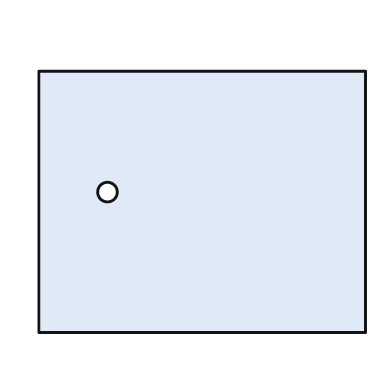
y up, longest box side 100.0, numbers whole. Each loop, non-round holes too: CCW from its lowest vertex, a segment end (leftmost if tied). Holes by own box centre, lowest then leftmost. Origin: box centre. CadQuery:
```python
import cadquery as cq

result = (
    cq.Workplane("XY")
    .moveTo(-50.0, -40.0)
    .lineTo(50.0, -40.0)
    .lineTo(50.0, 40.0)
    .lineTo(-50.0, 40.0)
    .close()
    .moveTo(-29.0, 3.0)
    .circle(3.0)
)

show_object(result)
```